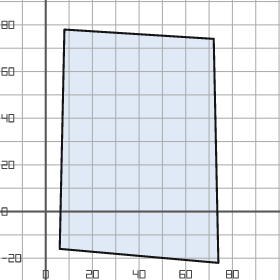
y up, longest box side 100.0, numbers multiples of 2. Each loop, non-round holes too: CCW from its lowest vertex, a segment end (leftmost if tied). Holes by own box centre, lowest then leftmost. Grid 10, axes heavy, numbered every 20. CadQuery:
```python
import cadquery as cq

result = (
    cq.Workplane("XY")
    .moveTo(74.0, -22.0)
    .lineTo(72.0, 74.0)
    .lineTo(8.0, 78.0)
    .lineTo(6.0, -16.0)
    .close()
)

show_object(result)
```